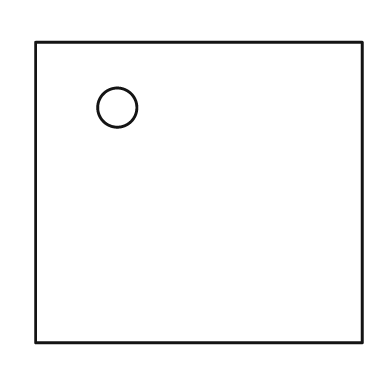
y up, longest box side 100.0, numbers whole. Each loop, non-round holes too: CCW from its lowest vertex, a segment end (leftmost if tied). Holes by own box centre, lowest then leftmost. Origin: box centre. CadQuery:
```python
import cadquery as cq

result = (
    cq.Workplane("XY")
    .moveTo(-50.0, -46.0)
    .lineTo(50.0, -46.0)
    .lineTo(50.0, 46.0)
    .lineTo(-50.0, 46.0)
    .close()
    .moveTo(-25.0, 26.0)
    .circle(6.0)
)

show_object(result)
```